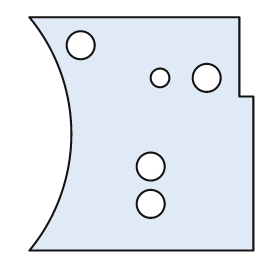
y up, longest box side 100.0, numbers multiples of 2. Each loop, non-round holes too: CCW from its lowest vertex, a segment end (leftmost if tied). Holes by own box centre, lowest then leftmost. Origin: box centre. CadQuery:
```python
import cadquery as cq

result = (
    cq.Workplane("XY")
    .moveTo(-48.0, -50.0)
    .lineTo(48.0, -50.0)
    .lineTo(48.0, 16.0)
    .lineTo(42.0, 16.0)
    .lineTo(42.0, 50.0)
    .lineTo(-48.0, 50.0)
    .threePointArc((-30.0, 0.0), (-48.0, -50.0))
    .close()
    .moveTo(4.0, -30.0)
    .circle(6.0)
    .moveTo(4.0, -14.0)
    .circle(6.0)
    .moveTo(8.0, 24.0)
    .circle(4.0)
    .moveTo(28.0, 24.0)
    .circle(6.0)
    .moveTo(-26.0, 38.0)
    .circle(6.0)
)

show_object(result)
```